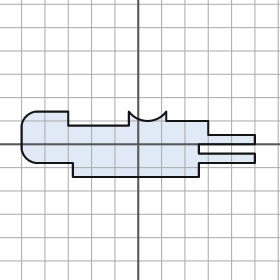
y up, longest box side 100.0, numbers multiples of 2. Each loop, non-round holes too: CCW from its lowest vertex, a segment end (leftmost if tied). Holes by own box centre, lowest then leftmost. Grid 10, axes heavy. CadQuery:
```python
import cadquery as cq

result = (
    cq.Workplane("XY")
    .moveTo(-28.0, -14.0)
    .lineTo(26.0, -14.0)
    .lineTo(26.0, -8.0)
    .lineTo(50.0, -8.0)
    .lineTo(50.0, -4.0)
    .lineTo(26.0, -4.0)
    .lineTo(26.0, 0.0)
    .lineTo(50.0, 0.0)
    .lineTo(50.0, 4.0)
    .lineTo(30.0, 4.0)
    .lineTo(30.0, 10.0)
    .lineTo(12.0, 10.0)
    .lineTo(12.0, 14.0)
    .threePointArc((4.0, 10.0), (-4.0, 14.0))
    .lineTo(-4.0, 8.0)
    .lineTo(-30.0, 8.0)
    .lineTo(-30.0, 14.0)
    .lineTo(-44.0, 14.0)
    .threePointArc((-48.0, 12.0), (-50.0, 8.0))
    .lineTo(-50.0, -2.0)
    .threePointArc((-48.0, -6.0), (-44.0, -8.0))
    .lineTo(-28.0, -8.0)
    .close()
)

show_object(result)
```